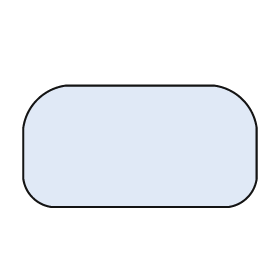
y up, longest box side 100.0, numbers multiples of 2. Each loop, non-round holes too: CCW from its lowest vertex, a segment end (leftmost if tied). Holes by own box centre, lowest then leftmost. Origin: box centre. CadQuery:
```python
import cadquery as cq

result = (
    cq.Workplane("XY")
    .moveTo(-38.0, -26.0)
    .lineTo(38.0, -26.0)
    .threePointArc((46.0, -22.0), (50.0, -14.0))
    .lineTo(50.0, 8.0)
    .threePointArc((44.0, 20.0), (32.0, 26.0))
    .lineTo(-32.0, 26.0)
    .threePointArc((-44.0, 20.0), (-50.0, 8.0))
    .lineTo(-50.0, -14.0)
    .threePointArc((-46.0, -22.0), (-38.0, -26.0))
    .close()
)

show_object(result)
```